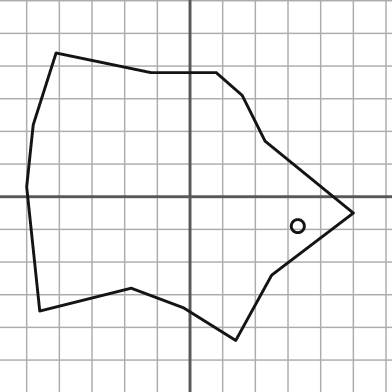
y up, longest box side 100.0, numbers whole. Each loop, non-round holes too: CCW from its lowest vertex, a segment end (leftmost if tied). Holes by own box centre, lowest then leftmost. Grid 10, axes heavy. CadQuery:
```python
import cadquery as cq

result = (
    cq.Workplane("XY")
    .moveTo(14.0, -44.0)
    .lineTo(25.0, -24.0)
    .lineTo(50.0, -5.0)
    .lineTo(23.0, 17.0)
    .lineTo(16.0, 31.0)
    .lineTo(8.0, 38.0)
    .lineTo(-12.0, 38.0)
    .lineTo(-41.0, 44.0)
    .lineTo(-48.0, 22.0)
    .lineTo(-50.0, 3.0)
    .lineTo(-46.0, -35.0)
    .lineTo(-18.0, -28.0)
    .lineTo(-2.0, -34.0)
    .close()
    .moveTo(33.0, -9.0)
    .circle(2.0)
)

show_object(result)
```